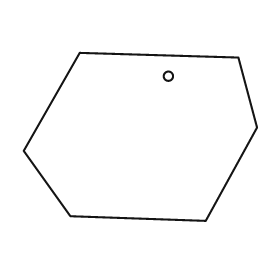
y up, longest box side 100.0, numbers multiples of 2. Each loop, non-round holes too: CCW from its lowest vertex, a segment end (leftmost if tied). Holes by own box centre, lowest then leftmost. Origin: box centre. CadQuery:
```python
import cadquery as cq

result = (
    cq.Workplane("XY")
    .moveTo(28.0, -36.0)
    .lineTo(50.0, 4.0)
    .lineTo(42.0, 34.0)
    .lineTo(-26.0, 36.0)
    .lineTo(-50.0, -6.0)
    .lineTo(-30.0, -34.0)
    .close()
    .moveTo(12.0, 26.0)
    .circle(2.0)
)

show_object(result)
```